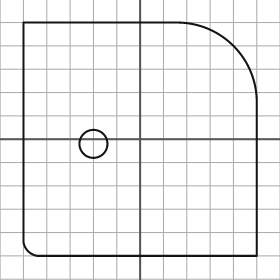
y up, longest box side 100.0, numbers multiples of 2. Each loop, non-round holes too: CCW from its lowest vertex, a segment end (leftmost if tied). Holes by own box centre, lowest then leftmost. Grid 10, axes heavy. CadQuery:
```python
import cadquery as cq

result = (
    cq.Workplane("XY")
    .moveTo(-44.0, -50.0)
    .lineTo(50.0, -50.0)
    .lineTo(50.0, 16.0)
    .threePointArc((40.0, 40.0), (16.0, 50.0))
    .lineTo(-50.0, 50.0)
    .lineTo(-50.0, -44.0)
    .threePointArc((-48.0, -48.0), (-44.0, -50.0))
    .close()
    .moveTo(-20.0, -2.0)
    .circle(6.0)
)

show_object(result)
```